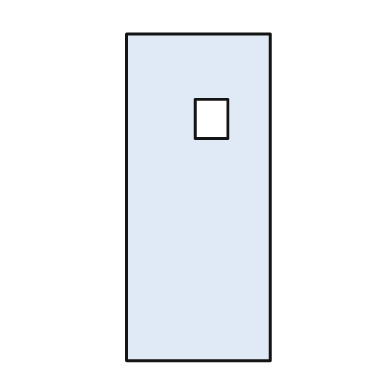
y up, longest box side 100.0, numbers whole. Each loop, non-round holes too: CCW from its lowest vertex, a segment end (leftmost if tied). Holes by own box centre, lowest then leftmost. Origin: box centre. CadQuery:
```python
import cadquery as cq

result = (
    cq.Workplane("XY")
    .moveTo(-22.0, -50.0)
    .lineTo(22.0, -50.0)
    .lineTo(22.0, 50.0)
    .lineTo(-22.0, 50.0)
    .close()
    .moveTo(-1.0, 18.0)
    .lineTo(9.0, 18.0)
    .lineTo(9.0, 30.0)
    .lineTo(-1.0, 30.0)
    .close()
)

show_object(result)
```